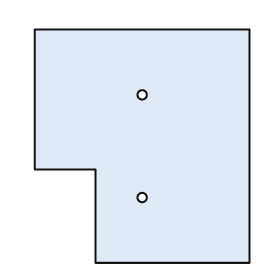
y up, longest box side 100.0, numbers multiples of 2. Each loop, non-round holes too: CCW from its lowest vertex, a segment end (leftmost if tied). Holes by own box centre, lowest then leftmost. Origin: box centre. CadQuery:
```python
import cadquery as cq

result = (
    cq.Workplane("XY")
    .moveTo(-20.0, -50.0)
    .lineTo(46.0, -50.0)
    .lineTo(46.0, 50.0)
    .lineTo(-46.0, 50.0)
    .lineTo(-46.0, -10.0)
    .lineTo(-20.0, -10.0)
    .close()
    .moveTo(0.0, -22.0)
    .circle(2.0)
    .moveTo(0.0, 22.0)
    .circle(2.0)
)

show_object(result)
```